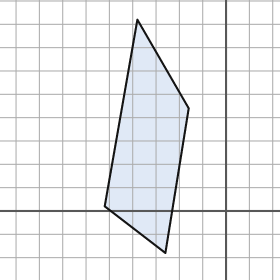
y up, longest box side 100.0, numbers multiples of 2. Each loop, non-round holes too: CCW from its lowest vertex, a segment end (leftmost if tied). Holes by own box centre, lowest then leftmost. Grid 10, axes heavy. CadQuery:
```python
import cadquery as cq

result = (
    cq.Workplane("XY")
    .moveTo(-26.0, -18.0)
    .lineTo(-16.0, 44.0)
    .lineTo(-38.0, 82.0)
    .lineTo(-52.0, 2.0)
    .close()
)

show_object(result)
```